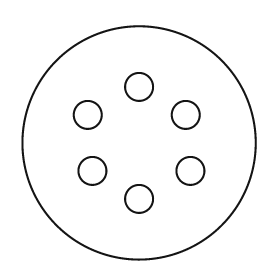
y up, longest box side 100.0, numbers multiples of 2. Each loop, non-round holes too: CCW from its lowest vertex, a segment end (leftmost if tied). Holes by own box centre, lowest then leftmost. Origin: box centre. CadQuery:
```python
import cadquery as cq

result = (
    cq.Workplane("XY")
    .moveTo(0.0, 0.0)
    .circle(50.0)
    .moveTo(0.0, -24.0)
    .circle(6.0)
    .moveTo(-20.0, -12.0)
    .circle(6.0)
    .moveTo(22.0, -12.0)
    .circle(6.0)
    .moveTo(-22.0, 12.0)
    .circle(6.0)
    .moveTo(20.0, 12.0)
    .circle(6.0)
    .moveTo(0.0, 24.0)
    .circle(6.0)
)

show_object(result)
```